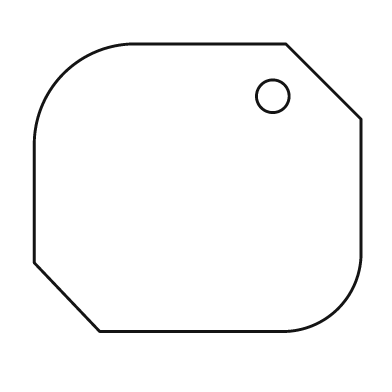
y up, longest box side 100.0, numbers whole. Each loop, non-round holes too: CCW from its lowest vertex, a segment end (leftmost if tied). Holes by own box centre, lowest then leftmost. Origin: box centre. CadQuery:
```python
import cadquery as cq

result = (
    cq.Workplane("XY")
    .moveTo(-30.0, -44.0)
    .lineTo(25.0, -44.0)
    .threePointArc((43.0, -37.0), (50.0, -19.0))
    .lineTo(50.0, 21.0)
    .lineTo(27.0, 44.0)
    .lineTo(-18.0, 44.0)
    .threePointArc((-41.0, 35.0), (-50.0, 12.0))
    .lineTo(-50.0, -23.0)
    .close()
    .moveTo(23.0, 28.0)
    .circle(5.0)
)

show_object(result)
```